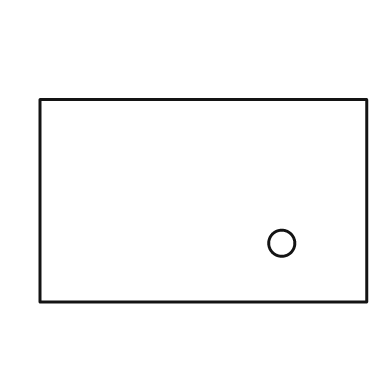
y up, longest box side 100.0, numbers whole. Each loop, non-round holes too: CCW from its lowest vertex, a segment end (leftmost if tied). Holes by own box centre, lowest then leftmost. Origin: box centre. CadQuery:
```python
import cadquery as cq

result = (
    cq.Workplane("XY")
    .moveTo(-50.0, -31.0)
    .lineTo(50.0, -31.0)
    .lineTo(50.0, 31.0)
    .lineTo(-50.0, 31.0)
    .close()
    .moveTo(24.0, -13.0)
    .circle(4.0)
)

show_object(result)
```